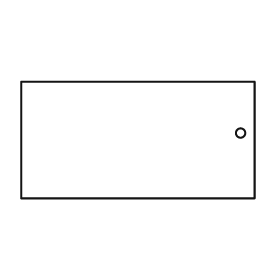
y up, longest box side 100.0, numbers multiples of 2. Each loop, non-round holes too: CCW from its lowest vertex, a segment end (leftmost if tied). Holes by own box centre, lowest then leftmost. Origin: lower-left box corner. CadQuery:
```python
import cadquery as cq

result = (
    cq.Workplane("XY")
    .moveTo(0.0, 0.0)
    .lineTo(100.0, 0.0)
    .lineTo(100.0, 50.0)
    .lineTo(0.0, 50.0)
    .close()
    .moveTo(94.0, 28.0)
    .circle(2.0)
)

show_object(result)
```